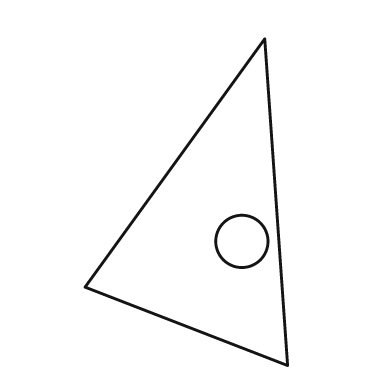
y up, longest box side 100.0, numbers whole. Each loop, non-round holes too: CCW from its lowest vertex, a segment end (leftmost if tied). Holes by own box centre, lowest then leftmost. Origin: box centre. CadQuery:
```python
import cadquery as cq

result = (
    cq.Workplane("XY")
    .moveTo(31.0, -50.0)
    .lineTo(24.0, 50.0)
    .lineTo(-31.0, -26.0)
    .close()
    .moveTo(17.0, -12.0)
    .circle(8.0)
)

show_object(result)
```